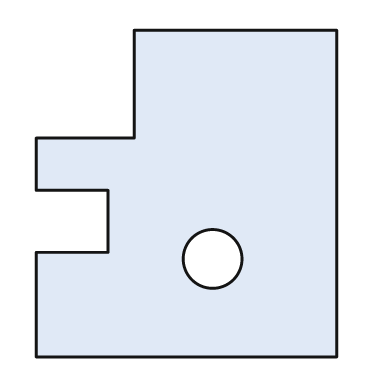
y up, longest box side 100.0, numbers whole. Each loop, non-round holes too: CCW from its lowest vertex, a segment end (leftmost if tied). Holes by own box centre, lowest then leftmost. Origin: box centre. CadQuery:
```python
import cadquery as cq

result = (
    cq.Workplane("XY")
    .moveTo(-46.0, -50.0)
    .lineTo(46.0, -50.0)
    .lineTo(46.0, 50.0)
    .lineTo(-16.0, 50.0)
    .lineTo(-16.0, 17.0)
    .lineTo(-46.0, 17.0)
    .lineTo(-46.0, 1.0)
    .lineTo(-24.0, 1.0)
    .lineTo(-24.0, -18.0)
    .lineTo(-46.0, -18.0)
    .close()
    .moveTo(8.0, -20.0)
    .circle(9.0)
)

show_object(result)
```